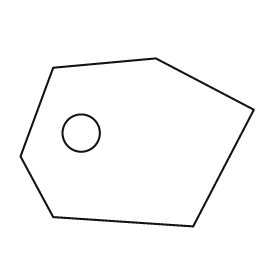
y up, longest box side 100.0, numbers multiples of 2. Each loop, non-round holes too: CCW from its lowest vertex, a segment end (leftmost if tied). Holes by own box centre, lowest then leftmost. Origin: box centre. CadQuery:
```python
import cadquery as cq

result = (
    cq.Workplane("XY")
    .moveTo(24.0, -36.0)
    .lineTo(50.0, 14.0)
    .lineTo(8.0, 36.0)
    .lineTo(-36.0, 32.0)
    .lineTo(-50.0, -6.0)
    .lineTo(-36.0, -32.0)
    .close()
    .moveTo(-24.0, 4.0)
    .circle(8.0)
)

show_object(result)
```